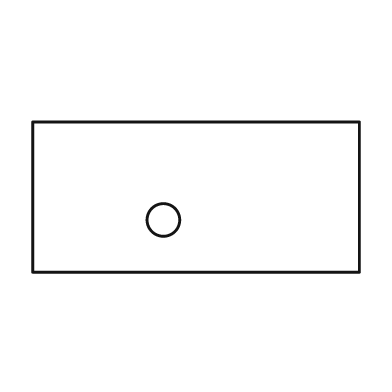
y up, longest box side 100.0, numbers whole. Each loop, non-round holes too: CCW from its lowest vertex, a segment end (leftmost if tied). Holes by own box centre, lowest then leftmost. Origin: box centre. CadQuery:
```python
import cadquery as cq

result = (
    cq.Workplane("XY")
    .moveTo(-50.0, -23.0)
    .lineTo(50.0, -23.0)
    .lineTo(50.0, 23.0)
    .lineTo(-50.0, 23.0)
    .close()
    .moveTo(-10.0, -7.0)
    .circle(5.0)
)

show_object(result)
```